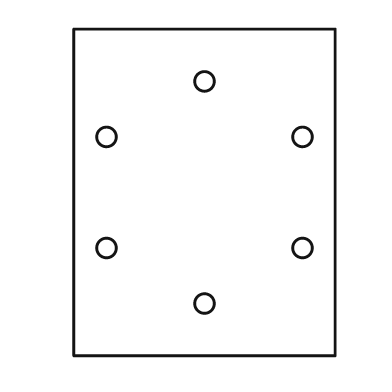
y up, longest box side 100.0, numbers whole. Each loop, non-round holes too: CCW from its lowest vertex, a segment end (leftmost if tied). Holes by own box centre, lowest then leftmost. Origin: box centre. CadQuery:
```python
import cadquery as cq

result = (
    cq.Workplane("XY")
    .moveTo(-40.0, -50.0)
    .lineTo(40.0, -50.0)
    .lineTo(40.0, 50.0)
    .lineTo(-40.0, 50.0)
    .close()
    .moveTo(0.0, -34.0)
    .circle(3.0)
    .moveTo(-30.0, -17.0)
    .circle(3.0)
    .moveTo(30.0, -17.0)
    .circle(3.0)
    .moveTo(-30.0, 17.0)
    .circle(3.0)
    .moveTo(30.0, 17.0)
    .circle(3.0)
    .moveTo(0.0, 34.0)
    .circle(3.0)
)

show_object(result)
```